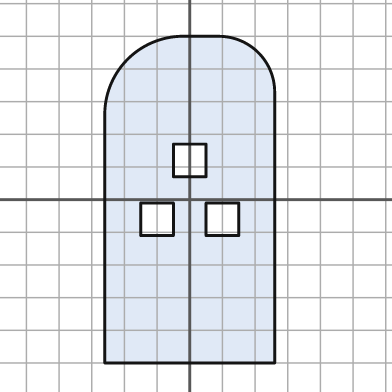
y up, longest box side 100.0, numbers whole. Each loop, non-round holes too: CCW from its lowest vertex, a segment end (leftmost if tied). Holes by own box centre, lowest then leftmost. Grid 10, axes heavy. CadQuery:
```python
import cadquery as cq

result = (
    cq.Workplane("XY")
    .moveTo(-26.0, -50.0)
    .lineTo(26.0, -50.0)
    .lineTo(26.0, 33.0)
    .threePointArc((21.0, 45.0), (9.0, 50.0))
    .lineTo(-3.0, 50.0)
    .threePointArc((-19.0, 43.0), (-26.0, 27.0))
    .close()
    .moveTo(-15.0, -11.0)
    .lineTo(-5.0, -11.0)
    .lineTo(-5.0, -1.0)
    .lineTo(-15.0, -1.0)
    .close()
    .moveTo(5.0, -11.0)
    .lineTo(15.0, -11.0)
    .lineTo(15.0, -1.0)
    .lineTo(5.0, -1.0)
    .close()
    .moveTo(-5.0, 7.0)
    .lineTo(5.0, 7.0)
    .lineTo(5.0, 17.0)
    .lineTo(-5.0, 17.0)
    .close()
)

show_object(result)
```